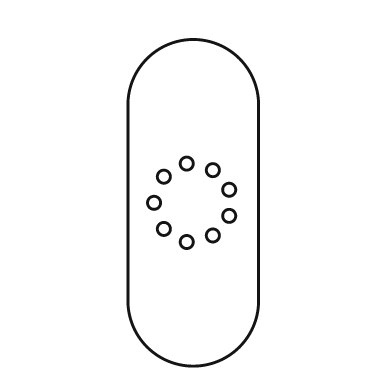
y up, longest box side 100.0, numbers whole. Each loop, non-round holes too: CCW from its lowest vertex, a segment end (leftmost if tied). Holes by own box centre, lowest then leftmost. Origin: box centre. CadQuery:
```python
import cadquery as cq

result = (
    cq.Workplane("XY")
    .moveTo(-20.0, -30.0)
    .threePointArc((0.0, -50.0), (20.0, -30.0))
    .lineTo(20.0, 30.0)
    .threePointArc((0.0, 50.0), (-20.0, 30.0))
    .close()
    .moveTo(-2.0, -12.0)
    .circle(2.0)
    .moveTo(6.0, -10.0)
    .circle(2.0)
    .moveTo(-9.0, -8.0)
    .circle(2.0)
    .moveTo(11.0, -4.0)
    .circle(2.0)
    .moveTo(-12.0, 0.0)
    .circle(2.0)
    .moveTo(11.0, 4.0)
    .circle(2.0)
    .moveTo(-9.0, 8.0)
    .circle(2.0)
    .moveTo(6.0, 10.0)
    .circle(2.0)
    .moveTo(-2.0, 12.0)
    .circle(2.0)
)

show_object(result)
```